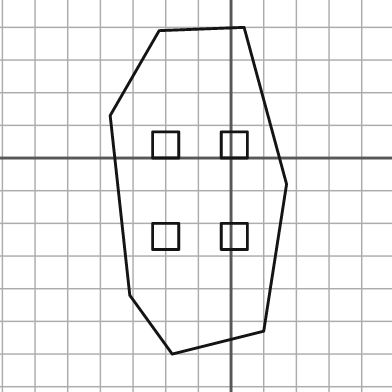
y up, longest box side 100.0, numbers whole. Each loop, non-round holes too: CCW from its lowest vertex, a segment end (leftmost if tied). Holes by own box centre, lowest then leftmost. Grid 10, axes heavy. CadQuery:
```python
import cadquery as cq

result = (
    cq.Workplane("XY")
    .moveTo(-18.0, -60.0)
    .lineTo(10.0, -53.0)
    .lineTo(17.0, -8.0)
    .lineTo(4.0, 40.0)
    .lineTo(-22.0, 39.0)
    .lineTo(-37.0, 13.0)
    .lineTo(-31.0, -42.0)
    .close()
    .moveTo(-24.0, -28.0)
    .lineTo(-16.0, -28.0)
    .lineTo(-16.0, -20.0)
    .lineTo(-24.0, -20.0)
    .close()
    .moveTo(-3.0, -28.0)
    .lineTo(5.0, -28.0)
    .lineTo(5.0, -20.0)
    .lineTo(-3.0, -20.0)
    .close()
    .moveTo(-24.0, 0.0)
    .lineTo(-16.0, 0.0)
    .lineTo(-16.0, 8.0)
    .lineTo(-24.0, 8.0)
    .close()
    .moveTo(-3.0, 0.0)
    .lineTo(5.0, 0.0)
    .lineTo(5.0, 8.0)
    .lineTo(-3.0, 8.0)
    .close()
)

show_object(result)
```